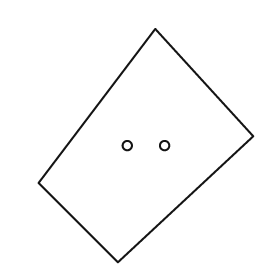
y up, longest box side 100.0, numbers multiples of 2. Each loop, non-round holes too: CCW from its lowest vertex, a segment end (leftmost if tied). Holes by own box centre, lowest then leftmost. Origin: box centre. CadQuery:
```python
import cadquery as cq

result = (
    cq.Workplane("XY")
    .moveTo(-12.0, -50.0)
    .lineTo(46.0, 4.0)
    .lineTo(4.0, 50.0)
    .lineTo(-46.0, -16.0)
    .close()
    .moveTo(-8.0, 0.0)
    .circle(2.0)
    .moveTo(8.0, 0.0)
    .circle(2.0)
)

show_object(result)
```